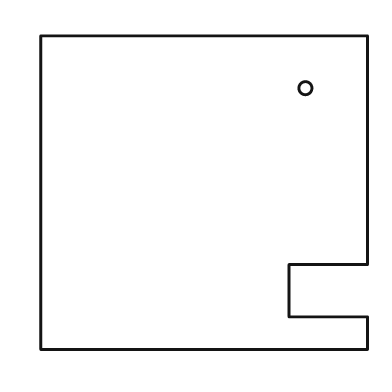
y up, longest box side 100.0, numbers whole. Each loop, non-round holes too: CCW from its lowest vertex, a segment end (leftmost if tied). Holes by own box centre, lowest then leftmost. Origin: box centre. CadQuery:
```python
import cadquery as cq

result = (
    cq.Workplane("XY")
    .moveTo(-50.0, -48.0)
    .lineTo(50.0, -48.0)
    .lineTo(50.0, -38.0)
    .lineTo(26.0, -38.0)
    .lineTo(26.0, -22.0)
    .lineTo(50.0, -22.0)
    .lineTo(50.0, 48.0)
    .lineTo(-50.0, 48.0)
    .close()
    .moveTo(31.0, 32.0)
    .circle(2.0)
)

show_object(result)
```